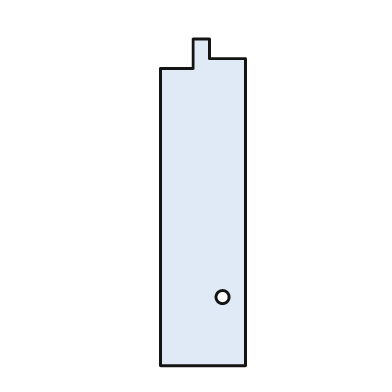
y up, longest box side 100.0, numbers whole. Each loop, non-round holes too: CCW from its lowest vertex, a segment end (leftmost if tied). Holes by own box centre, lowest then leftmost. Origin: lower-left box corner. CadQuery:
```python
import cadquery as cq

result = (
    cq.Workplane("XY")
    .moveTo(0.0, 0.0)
    .lineTo(26.0, 0.0)
    .lineTo(26.0, 94.0)
    .lineTo(15.0, 94.0)
    .lineTo(15.0, 100.0)
    .lineTo(10.0, 100.0)
    .lineTo(10.0, 91.0)
    .lineTo(0.0, 91.0)
    .close()
    .moveTo(19.0, 21.0)
    .circle(2.0)
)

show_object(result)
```